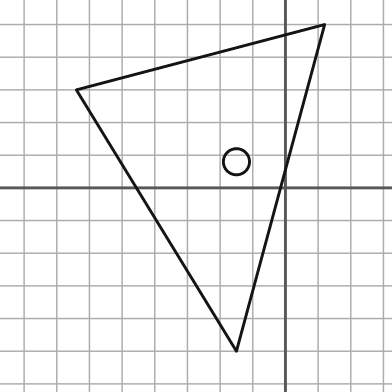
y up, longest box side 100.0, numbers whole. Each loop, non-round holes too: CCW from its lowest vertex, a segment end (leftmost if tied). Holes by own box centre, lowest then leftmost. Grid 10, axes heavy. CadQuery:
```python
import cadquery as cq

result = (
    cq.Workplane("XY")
    .moveTo(-15.0, -50.0)
    .lineTo(12.0, 50.0)
    .lineTo(-64.0, 30.0)
    .close()
    .moveTo(-15.0, 8.0)
    .circle(4.0)
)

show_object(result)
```